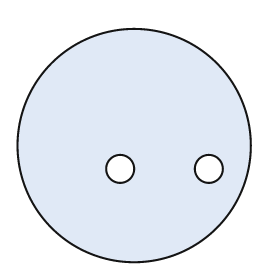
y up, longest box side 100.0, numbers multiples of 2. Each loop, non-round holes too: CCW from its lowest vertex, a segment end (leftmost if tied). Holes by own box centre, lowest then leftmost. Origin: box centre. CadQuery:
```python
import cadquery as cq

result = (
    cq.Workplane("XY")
    .moveTo(0.0, 0.0)
    .circle(50.0)
    .moveTo(-6.0, -10.0)
    .circle(6.0)
    .moveTo(32.0, -10.0)
    .circle(6.0)
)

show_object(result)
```